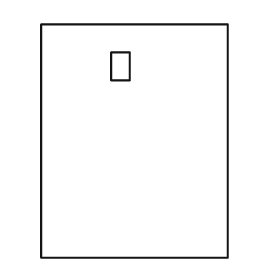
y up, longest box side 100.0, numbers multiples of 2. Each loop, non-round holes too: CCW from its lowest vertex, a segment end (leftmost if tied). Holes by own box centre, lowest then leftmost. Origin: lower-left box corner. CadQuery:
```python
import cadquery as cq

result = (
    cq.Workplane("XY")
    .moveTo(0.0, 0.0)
    .lineTo(80.0, 0.0)
    .lineTo(80.0, 100.0)
    .lineTo(0.0, 100.0)
    .close()
    .moveTo(30.0, 76.0)
    .lineTo(38.0, 76.0)
    .lineTo(38.0, 88.0)
    .lineTo(30.0, 88.0)
    .close()
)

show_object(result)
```